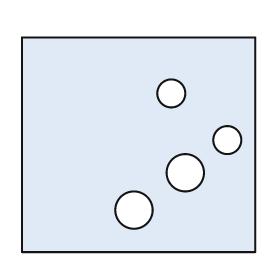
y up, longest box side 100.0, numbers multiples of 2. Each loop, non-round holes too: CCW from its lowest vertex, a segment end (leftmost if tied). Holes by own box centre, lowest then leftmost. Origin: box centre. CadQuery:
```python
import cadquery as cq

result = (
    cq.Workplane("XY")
    .moveTo(-50.0, -46.0)
    .lineTo(50.0, -46.0)
    .lineTo(50.0, 46.0)
    .lineTo(-50.0, 46.0)
    .close()
    .moveTo(-2.0, -28.0)
    .circle(8.0)
    .moveTo(20.0, -12.0)
    .circle(8.0)
    .moveTo(38.0, 2.0)
    .circle(6.0)
    .moveTo(14.0, 22.0)
    .circle(6.0)
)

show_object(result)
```